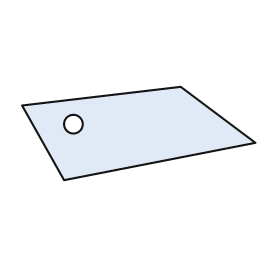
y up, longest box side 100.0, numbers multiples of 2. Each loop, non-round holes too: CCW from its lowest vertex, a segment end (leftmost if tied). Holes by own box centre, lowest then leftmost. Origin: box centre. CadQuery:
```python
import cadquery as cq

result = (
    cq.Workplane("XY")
    .moveTo(-32.0, -20.0)
    .lineTo(50.0, -4.0)
    .lineTo(18.0, 20.0)
    .lineTo(-50.0, 12.0)
    .close()
    .moveTo(-28.0, 4.0)
    .circle(4.0)
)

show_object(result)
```